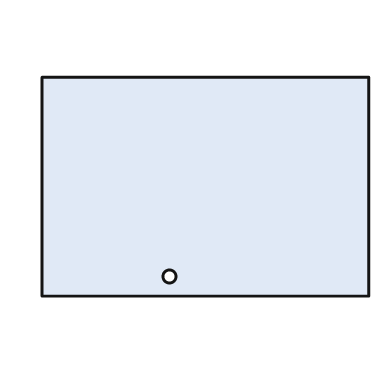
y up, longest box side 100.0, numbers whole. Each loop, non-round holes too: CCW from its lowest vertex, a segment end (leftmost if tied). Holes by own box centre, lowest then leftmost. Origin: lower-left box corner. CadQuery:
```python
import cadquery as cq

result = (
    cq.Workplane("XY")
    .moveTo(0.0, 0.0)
    .lineTo(100.0, 0.0)
    .lineTo(100.0, 67.0)
    .lineTo(0.0, 67.0)
    .close()
    .moveTo(39.0, 6.0)
    .circle(2.0)
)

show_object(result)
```